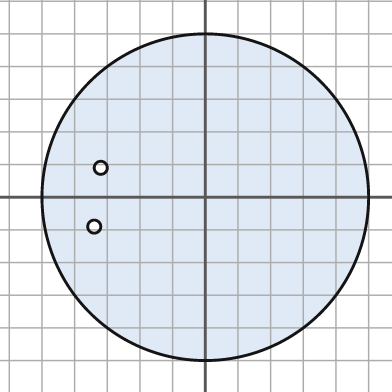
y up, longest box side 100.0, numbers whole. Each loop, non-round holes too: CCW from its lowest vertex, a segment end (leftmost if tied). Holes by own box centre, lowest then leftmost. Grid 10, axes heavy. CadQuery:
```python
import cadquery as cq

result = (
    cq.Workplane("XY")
    .moveTo(0.0, 0.0)
    .circle(50.0)
    .moveTo(-34.0, -9.0)
    .circle(2.0)
    .moveTo(-32.0, 9.0)
    .circle(2.0)
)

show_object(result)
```